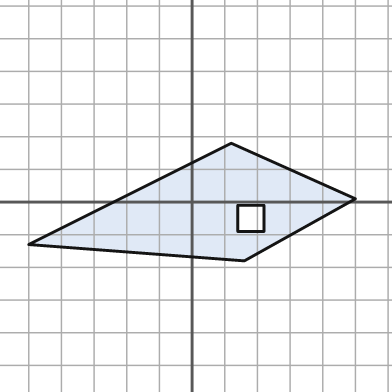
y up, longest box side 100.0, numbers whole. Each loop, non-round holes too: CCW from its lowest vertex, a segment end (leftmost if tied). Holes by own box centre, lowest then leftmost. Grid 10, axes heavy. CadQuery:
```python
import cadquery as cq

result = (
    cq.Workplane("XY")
    .moveTo(16.0, -18.0)
    .lineTo(50.0, 1.0)
    .lineTo(12.0, 18.0)
    .lineTo(-50.0, -13.0)
    .close()
    .moveTo(14.0, -9.0)
    .lineTo(22.0, -9.0)
    .lineTo(22.0, -1.0)
    .lineTo(14.0, -1.0)
    .close()
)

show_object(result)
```